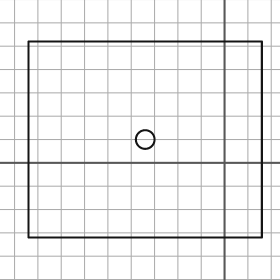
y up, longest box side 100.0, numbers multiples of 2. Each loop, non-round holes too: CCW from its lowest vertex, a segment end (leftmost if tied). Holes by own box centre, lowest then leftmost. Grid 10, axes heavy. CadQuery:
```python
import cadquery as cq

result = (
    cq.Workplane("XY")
    .moveTo(-84.0, -32.0)
    .lineTo(16.0, -32.0)
    .lineTo(16.0, 52.0)
    .lineTo(-84.0, 52.0)
    .close()
    .moveTo(-34.0, 10.0)
    .circle(4.0)
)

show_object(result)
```